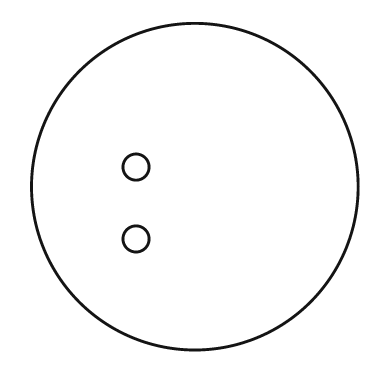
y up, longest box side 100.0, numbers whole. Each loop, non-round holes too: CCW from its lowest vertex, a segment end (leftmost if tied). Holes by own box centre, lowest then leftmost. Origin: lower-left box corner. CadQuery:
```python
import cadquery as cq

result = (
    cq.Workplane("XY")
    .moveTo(50.0, 50.0)
    .circle(50.0)
    .moveTo(32.0, 34.0)
    .circle(4.0)
    .moveTo(32.0, 56.0)
    .circle(4.0)
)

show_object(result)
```